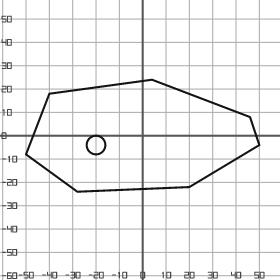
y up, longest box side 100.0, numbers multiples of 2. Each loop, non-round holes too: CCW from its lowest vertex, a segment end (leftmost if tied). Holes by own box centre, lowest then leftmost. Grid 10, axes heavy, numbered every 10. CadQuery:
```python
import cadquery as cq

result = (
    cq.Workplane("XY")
    .moveTo(-28.0, -24.0)
    .lineTo(20.0, -22.0)
    .lineTo(50.0, -4.0)
    .lineTo(46.0, 8.0)
    .lineTo(4.0, 24.0)
    .lineTo(-40.0, 18.0)
    .lineTo(-50.0, -8.0)
    .close()
    .moveTo(-20.0, -4.0)
    .circle(4.0)
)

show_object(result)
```